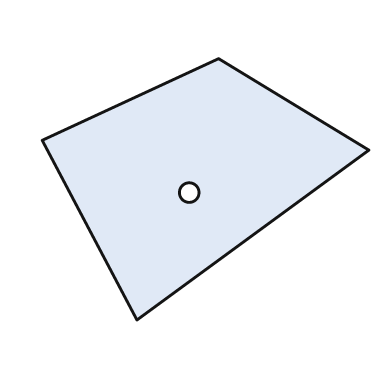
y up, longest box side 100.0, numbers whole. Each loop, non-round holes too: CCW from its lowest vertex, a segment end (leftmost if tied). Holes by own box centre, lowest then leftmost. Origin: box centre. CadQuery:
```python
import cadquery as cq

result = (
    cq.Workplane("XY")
    .moveTo(-21.0, -40.0)
    .lineTo(50.0, 12.0)
    .lineTo(4.0, 40.0)
    .lineTo(-50.0, 15.0)
    .close()
    .moveTo(-5.0, -1.0)
    .circle(3.0)
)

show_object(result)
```